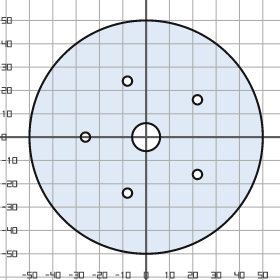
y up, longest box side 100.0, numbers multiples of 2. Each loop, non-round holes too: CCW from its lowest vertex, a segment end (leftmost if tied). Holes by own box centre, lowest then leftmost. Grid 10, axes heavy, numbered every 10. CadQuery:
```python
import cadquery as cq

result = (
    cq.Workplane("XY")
    .moveTo(0.0, 0.0)
    .circle(50.0)
    .moveTo(-8.0, -24.0)
    .circle(2.0)
    .moveTo(22.0, -16.0)
    .circle(2.0)
    .moveTo(-26.0, 0.0)
    .circle(2.0)
    .moveTo(0.0, 0.0)
    .circle(6.0)
    .moveTo(22.0, 16.0)
    .circle(2.0)
    .moveTo(-8.0, 24.0)
    .circle(2.0)
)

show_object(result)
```